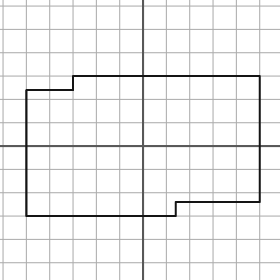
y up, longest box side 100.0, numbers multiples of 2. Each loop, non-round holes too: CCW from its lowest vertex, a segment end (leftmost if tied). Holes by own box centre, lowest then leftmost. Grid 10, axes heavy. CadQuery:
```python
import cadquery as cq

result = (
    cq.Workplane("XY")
    .moveTo(-50.0, -30.0)
    .lineTo(14.0, -30.0)
    .lineTo(14.0, -24.0)
    .lineTo(50.0, -24.0)
    .lineTo(50.0, 30.0)
    .lineTo(-30.0, 30.0)
    .lineTo(-30.0, 24.0)
    .lineTo(-50.0, 24.0)
    .close()
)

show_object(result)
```